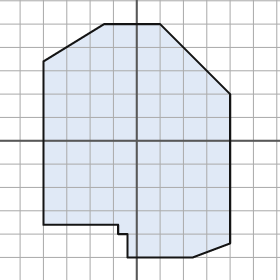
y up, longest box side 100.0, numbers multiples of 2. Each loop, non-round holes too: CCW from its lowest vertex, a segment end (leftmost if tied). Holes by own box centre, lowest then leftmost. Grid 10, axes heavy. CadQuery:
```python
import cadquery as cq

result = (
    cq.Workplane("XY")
    .moveTo(-4.0, -50.0)
    .lineTo(24.0, -50.0)
    .lineTo(40.0, -44.0)
    .lineTo(40.0, 20.0)
    .lineTo(10.0, 50.0)
    .lineTo(-14.0, 50.0)
    .lineTo(-40.0, 34.0)
    .lineTo(-40.0, -36.0)
    .lineTo(-8.0, -36.0)
    .lineTo(-8.0, -40.0)
    .lineTo(-4.0, -40.0)
    .close()
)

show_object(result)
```